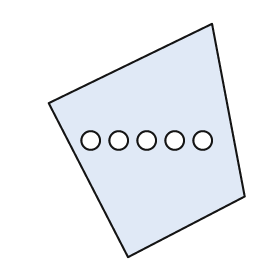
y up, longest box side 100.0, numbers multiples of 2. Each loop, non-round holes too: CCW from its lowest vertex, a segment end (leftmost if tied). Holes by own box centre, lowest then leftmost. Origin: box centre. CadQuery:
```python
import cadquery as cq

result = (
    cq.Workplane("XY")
    .moveTo(-8.0, -50.0)
    .lineTo(42.0, -24.0)
    .lineTo(28.0, 50.0)
    .lineTo(-42.0, 16.0)
    .close()
    .moveTo(-24.0, 0.0)
    .circle(4.0)
    .moveTo(-12.0, 0.0)
    .circle(4.0)
    .moveTo(0.0, 0.0)
    .circle(4.0)
    .moveTo(12.0, 0.0)
    .circle(4.0)
    .moveTo(24.0, 0.0)
    .circle(4.0)
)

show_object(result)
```